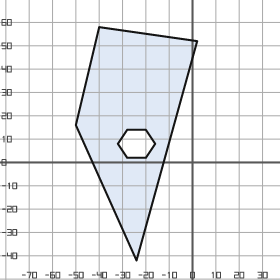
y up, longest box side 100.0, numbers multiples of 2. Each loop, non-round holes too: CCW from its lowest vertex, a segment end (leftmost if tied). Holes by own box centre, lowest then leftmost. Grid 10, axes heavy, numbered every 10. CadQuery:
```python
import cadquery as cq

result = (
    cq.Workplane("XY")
    .moveTo(-24.0, -42.0)
    .lineTo(2.0, 52.0)
    .lineTo(-40.0, 58.0)
    .lineTo(-50.0, 16.0)
    .close()
    .moveTo(-28.0, 2.0)
    .lineTo(-20.0, 2.0)
    .lineTo(-16.0, 8.0)
    .lineTo(-20.0, 14.0)
    .lineTo(-28.0, 14.0)
    .lineTo(-32.0, 8.0)
    .close()
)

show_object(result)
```